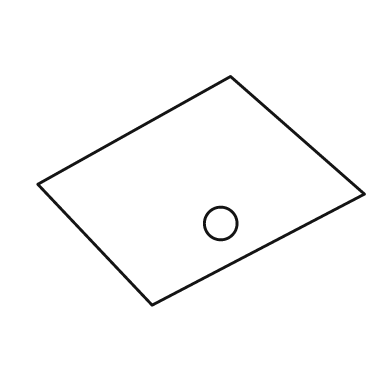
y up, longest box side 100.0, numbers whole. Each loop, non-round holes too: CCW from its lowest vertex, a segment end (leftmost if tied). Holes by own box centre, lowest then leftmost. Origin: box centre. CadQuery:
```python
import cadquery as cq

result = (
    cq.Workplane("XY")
    .moveTo(-15.0, -35.0)
    .lineTo(50.0, -1.0)
    .lineTo(9.0, 35.0)
    .lineTo(-50.0, 2.0)
    .close()
    .moveTo(6.0, -10.0)
    .circle(5.0)
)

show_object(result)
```